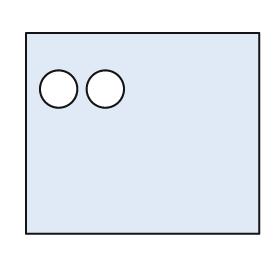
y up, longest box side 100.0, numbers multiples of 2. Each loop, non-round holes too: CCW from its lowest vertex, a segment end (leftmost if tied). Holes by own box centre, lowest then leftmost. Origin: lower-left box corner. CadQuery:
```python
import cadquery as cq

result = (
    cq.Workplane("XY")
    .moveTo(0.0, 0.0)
    .lineTo(100.0, 0.0)
    .lineTo(100.0, 86.0)
    .lineTo(0.0, 86.0)
    .close()
    .moveTo(14.0, 62.0)
    .circle(8.0)
    .moveTo(34.0, 62.0)
    .circle(8.0)
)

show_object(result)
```